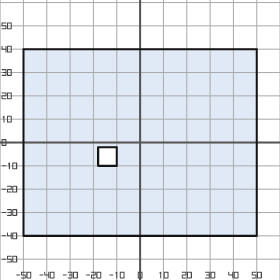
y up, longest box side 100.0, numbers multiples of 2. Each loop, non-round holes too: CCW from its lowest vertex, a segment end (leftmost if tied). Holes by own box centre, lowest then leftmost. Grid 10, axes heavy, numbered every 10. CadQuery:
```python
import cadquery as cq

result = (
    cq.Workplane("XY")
    .moveTo(-50.0, -40.0)
    .lineTo(50.0, -40.0)
    .lineTo(50.0, 40.0)
    .lineTo(-50.0, 40.0)
    .close()
    .moveTo(-18.0, -10.0)
    .lineTo(-10.0, -10.0)
    .lineTo(-10.0, -2.0)
    .lineTo(-18.0, -2.0)
    .close()
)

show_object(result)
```